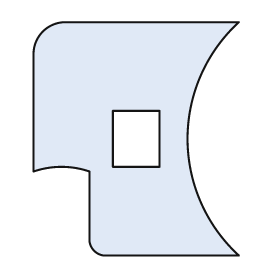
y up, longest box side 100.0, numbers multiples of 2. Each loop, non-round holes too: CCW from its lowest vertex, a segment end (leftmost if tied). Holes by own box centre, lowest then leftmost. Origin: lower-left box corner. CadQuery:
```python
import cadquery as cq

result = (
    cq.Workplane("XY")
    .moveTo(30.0, 0.0)
    .lineTo(88.0, 0.0)
    .threePointArc((66.0, 50.0), (88.0, 100.0))
    .lineTo(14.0, 100.0)
    .threePointArc((4.0, 96.0), (0.0, 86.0))
    .lineTo(0.0, 36.0)
    .threePointArc((12.0, 38.0), (24.0, 36.0))
    .lineTo(24.0, 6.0)
    .threePointArc((26.0, 2.0), (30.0, 0.0))
    .close()
    .moveTo(34.0, 38.0)
    .lineTo(54.0, 38.0)
    .lineTo(54.0, 62.0)
    .lineTo(34.0, 62.0)
    .close()
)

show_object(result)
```